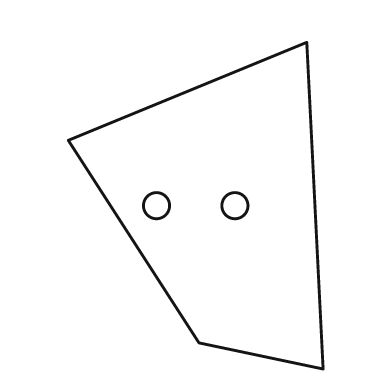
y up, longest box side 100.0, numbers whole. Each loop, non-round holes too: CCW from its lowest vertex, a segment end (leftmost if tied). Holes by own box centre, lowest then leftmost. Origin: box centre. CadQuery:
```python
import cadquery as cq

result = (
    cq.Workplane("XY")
    .moveTo(39.0, -50.0)
    .lineTo(34.0, 50.0)
    .lineTo(-39.0, 20.0)
    .lineTo(1.0, -42.0)
    .close()
    .moveTo(-12.0, 0.0)
    .circle(4.0)
    .moveTo(12.0, 0.0)
    .circle(4.0)
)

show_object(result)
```